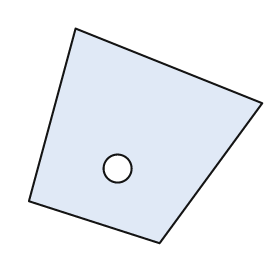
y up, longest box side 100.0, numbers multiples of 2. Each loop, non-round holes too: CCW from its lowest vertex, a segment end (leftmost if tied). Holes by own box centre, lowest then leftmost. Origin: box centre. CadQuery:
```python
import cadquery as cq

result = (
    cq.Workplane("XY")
    .moveTo(6.0, -46.0)
    .lineTo(50.0, 14.0)
    .lineTo(-30.0, 46.0)
    .lineTo(-50.0, -28.0)
    .close()
    .moveTo(-12.0, -14.0)
    .circle(6.0)
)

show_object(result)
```